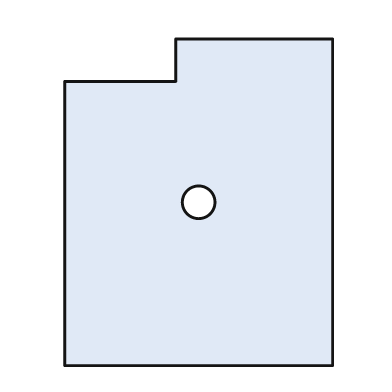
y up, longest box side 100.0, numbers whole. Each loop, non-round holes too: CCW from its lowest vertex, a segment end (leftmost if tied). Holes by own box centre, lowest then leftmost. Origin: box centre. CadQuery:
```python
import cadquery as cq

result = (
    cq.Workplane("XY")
    .moveTo(-41.0, -50.0)
    .lineTo(41.0, -50.0)
    .lineTo(41.0, 50.0)
    .lineTo(-7.0, 50.0)
    .lineTo(-7.0, 37.0)
    .lineTo(-41.0, 37.0)
    .close()
    .moveTo(0.0, 0.0)
    .circle(5.0)
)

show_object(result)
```